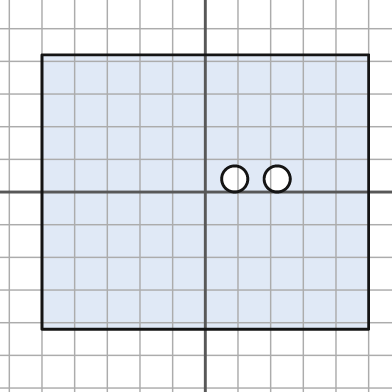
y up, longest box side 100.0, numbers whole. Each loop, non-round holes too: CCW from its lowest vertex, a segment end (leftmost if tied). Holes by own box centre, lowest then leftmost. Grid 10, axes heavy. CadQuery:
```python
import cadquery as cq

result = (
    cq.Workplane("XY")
    .moveTo(-50.0, -42.0)
    .lineTo(50.0, -42.0)
    .lineTo(50.0, 42.0)
    .lineTo(-50.0, 42.0)
    .close()
    .moveTo(9.0, 4.0)
    .circle(4.0)
    .moveTo(22.0, 4.0)
    .circle(4.0)
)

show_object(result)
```